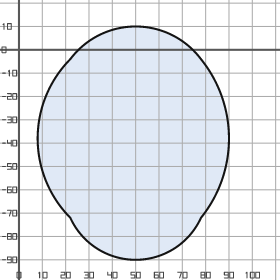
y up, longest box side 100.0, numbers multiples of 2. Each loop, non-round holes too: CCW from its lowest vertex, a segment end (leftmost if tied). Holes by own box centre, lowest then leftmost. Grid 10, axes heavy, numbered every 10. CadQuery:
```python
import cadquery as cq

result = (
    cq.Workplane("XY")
    .moveTo(22.0, -72.0)
    .threePointArc((50.0, -90.0), (78.0, -72.0))
    .threePointArc((90.0, -38.0), (78.0, -4.0))
    .threePointArc((50.0, 10.0), (22.0, -4.0))
    .threePointArc((8.0, -38.0), (22.0, -72.0))
    .close()
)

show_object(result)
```